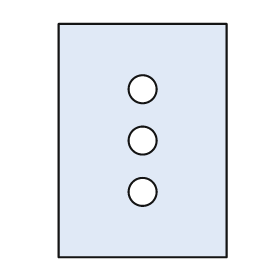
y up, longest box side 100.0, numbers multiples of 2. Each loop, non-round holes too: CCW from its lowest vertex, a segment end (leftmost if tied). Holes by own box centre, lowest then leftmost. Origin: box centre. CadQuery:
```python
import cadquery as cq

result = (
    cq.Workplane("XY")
    .moveTo(-36.0, -50.0)
    .lineTo(36.0, -50.0)
    .lineTo(36.0, 50.0)
    .lineTo(-36.0, 50.0)
    .close()
    .moveTo(0.0, -22.0)
    .circle(6.0)
    .moveTo(0.0, 0.0)
    .circle(6.0)
    .moveTo(0.0, 22.0)
    .circle(6.0)
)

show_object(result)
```